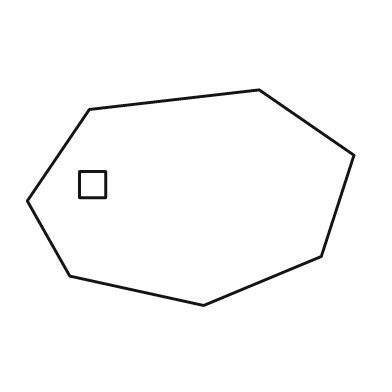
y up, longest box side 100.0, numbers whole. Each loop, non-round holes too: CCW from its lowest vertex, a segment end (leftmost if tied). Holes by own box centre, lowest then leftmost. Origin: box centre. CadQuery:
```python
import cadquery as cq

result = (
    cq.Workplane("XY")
    .moveTo(4.0, -33.0)
    .lineTo(40.0, -18.0)
    .lineTo(50.0, 13.0)
    .lineTo(21.0, 33.0)
    .lineTo(-31.0, 27.0)
    .lineTo(-50.0, -1.0)
    .lineTo(-37.0, -24.0)
    .close()
    .moveTo(-34.0, 0.0)
    .lineTo(-26.0, 0.0)
    .lineTo(-26.0, 8.0)
    .lineTo(-34.0, 8.0)
    .close()
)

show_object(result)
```